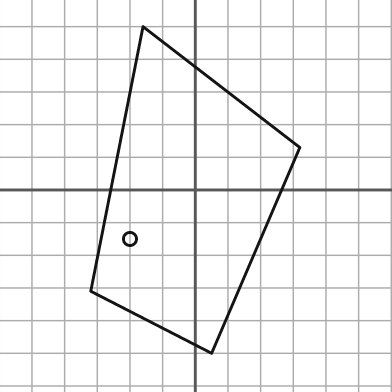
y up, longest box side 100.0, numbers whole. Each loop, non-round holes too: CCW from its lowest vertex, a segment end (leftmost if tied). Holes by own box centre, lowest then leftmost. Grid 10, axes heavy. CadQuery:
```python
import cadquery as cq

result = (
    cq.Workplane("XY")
    .moveTo(5.0, -50.0)
    .lineTo(32.0, 13.0)
    .lineTo(-16.0, 50.0)
    .lineTo(-32.0, -31.0)
    .close()
    .moveTo(-20.0, -15.0)
    .circle(2.0)
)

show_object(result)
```